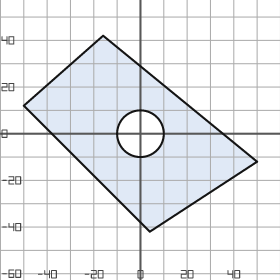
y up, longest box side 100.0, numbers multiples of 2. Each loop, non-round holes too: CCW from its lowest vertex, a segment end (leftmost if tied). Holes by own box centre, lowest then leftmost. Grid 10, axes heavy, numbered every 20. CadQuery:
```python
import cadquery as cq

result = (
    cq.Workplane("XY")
    .moveTo(4.0, -42.0)
    .lineTo(50.0, -12.0)
    .lineTo(-16.0, 42.0)
    .lineTo(-50.0, 12.0)
    .close()
    .moveTo(0.0, 0.0)
    .circle(10.0)
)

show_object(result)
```